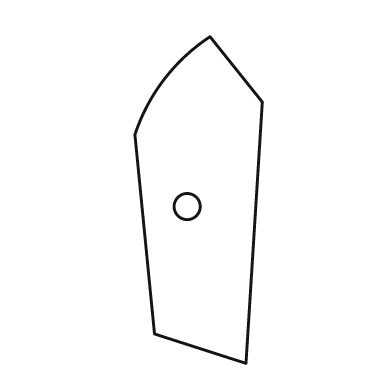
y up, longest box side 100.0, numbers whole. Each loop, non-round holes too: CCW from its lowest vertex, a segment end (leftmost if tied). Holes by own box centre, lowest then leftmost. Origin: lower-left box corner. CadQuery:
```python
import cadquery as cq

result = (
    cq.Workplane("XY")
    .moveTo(34.0, 0.0)
    .lineTo(39.0, 80.0)
    .lineTo(23.0, 100.0)
    .threePointArc((9.0, 87.0), (0.0, 70.0))
    .lineTo(6.0, 9.0)
    .close()
    .moveTo(16.0, 48.0)
    .circle(4.0)
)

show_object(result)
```